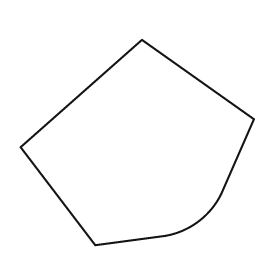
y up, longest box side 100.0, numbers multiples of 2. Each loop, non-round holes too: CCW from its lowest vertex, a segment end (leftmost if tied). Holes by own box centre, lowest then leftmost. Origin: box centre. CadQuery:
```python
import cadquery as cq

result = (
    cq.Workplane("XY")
    .moveTo(-18.0, -44.0)
    .lineTo(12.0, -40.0)
    .threePointArc((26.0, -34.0), (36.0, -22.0))
    .lineTo(50.0, 10.0)
    .lineTo(2.0, 44.0)
    .lineTo(-50.0, -2.0)
    .close()
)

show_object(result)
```